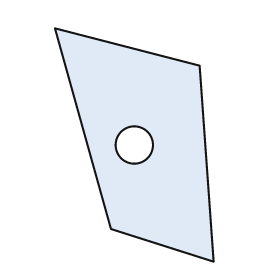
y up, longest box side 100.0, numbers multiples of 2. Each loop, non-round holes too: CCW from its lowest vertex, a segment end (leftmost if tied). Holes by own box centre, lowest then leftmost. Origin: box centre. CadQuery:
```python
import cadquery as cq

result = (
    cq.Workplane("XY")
    .moveTo(34.0, -50.0)
    .lineTo(28.0, 34.0)
    .lineTo(-34.0, 50.0)
    .lineTo(-10.0, -36.0)
    .close()
    .moveTo(0.0, 0.0)
    .circle(8.0)
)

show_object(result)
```